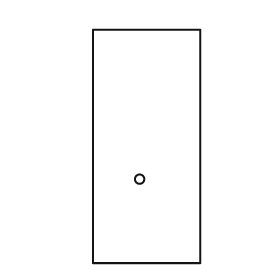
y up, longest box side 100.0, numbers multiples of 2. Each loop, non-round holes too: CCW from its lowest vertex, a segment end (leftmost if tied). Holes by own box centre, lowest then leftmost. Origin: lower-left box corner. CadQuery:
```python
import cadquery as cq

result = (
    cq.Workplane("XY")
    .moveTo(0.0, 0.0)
    .lineTo(46.0, 0.0)
    .lineTo(46.0, 100.0)
    .lineTo(0.0, 100.0)
    .close()
    .moveTo(20.0, 36.0)
    .circle(2.0)
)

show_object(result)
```